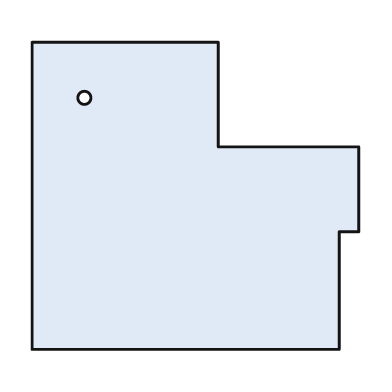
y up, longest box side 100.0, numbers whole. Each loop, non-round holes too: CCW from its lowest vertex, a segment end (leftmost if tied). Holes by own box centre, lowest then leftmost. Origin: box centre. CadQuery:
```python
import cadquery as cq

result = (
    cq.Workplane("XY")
    .moveTo(-50.0, -47.0)
    .lineTo(44.0, -47.0)
    .lineTo(44.0, -11.0)
    .lineTo(50.0, -11.0)
    .lineTo(50.0, 15.0)
    .lineTo(7.0, 15.0)
    .lineTo(7.0, 47.0)
    .lineTo(-50.0, 47.0)
    .close()
    .moveTo(-34.0, 30.0)
    .circle(2.0)
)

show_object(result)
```